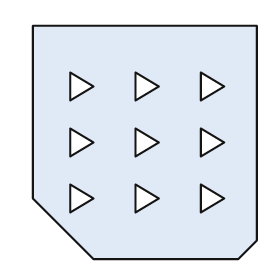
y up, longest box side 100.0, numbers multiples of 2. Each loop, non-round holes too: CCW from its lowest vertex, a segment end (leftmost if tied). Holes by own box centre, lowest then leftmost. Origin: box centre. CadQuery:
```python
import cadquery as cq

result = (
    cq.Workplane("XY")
    .moveTo(-22.0, -50.0)
    .lineTo(40.0, -50.0)
    .lineTo(48.0, -42.0)
    .lineTo(48.0, 50.0)
    .lineTo(-48.0, 50.0)
    .lineTo(-48.0, -24.0)
    .close()
    .moveTo(-32.0, -30.0)
    .lineTo(-22.0, -24.0)
    .lineTo(-32.0, -18.0)
    .close()
    .moveTo(-4.0, -30.0)
    .lineTo(6.0, -24.0)
    .lineTo(-4.0, -18.0)
    .close()
    .moveTo(24.0, -30.0)
    .lineTo(34.0, -24.0)
    .lineTo(24.0, -18.0)
    .close()
    .moveTo(-32.0, -6.0)
    .lineTo(-22.0, 0.0)
    .lineTo(-32.0, 6.0)
    .close()
    .moveTo(-4.0, -6.0)
    .lineTo(6.0, 0.0)
    .lineTo(-4.0, 6.0)
    .close()
    .moveTo(24.0, -6.0)
    .lineTo(34.0, 0.0)
    .lineTo(24.0, 6.0)
    .close()
    .moveTo(-32.0, 18.0)
    .lineTo(-22.0, 24.0)
    .lineTo(-32.0, 30.0)
    .close()
    .moveTo(-4.0, 18.0)
    .lineTo(6.0, 24.0)
    .lineTo(-4.0, 30.0)
    .close()
    .moveTo(24.0, 18.0)
    .lineTo(34.0, 24.0)
    .lineTo(24.0, 30.0)
    .close()
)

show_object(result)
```